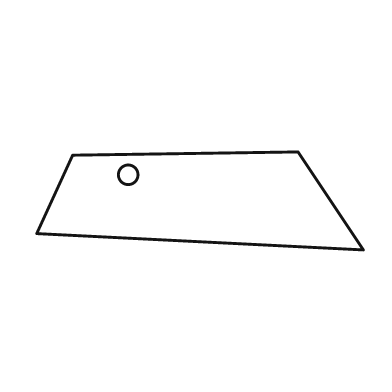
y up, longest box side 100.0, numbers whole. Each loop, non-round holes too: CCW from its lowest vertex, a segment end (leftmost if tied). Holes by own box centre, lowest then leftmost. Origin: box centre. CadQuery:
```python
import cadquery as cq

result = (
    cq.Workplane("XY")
    .moveTo(50.0, -15.0)
    .lineTo(30.0, 15.0)
    .lineTo(-39.0, 14.0)
    .lineTo(-50.0, -10.0)
    .close()
    .moveTo(-22.0, 8.0)
    .circle(3.0)
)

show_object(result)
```